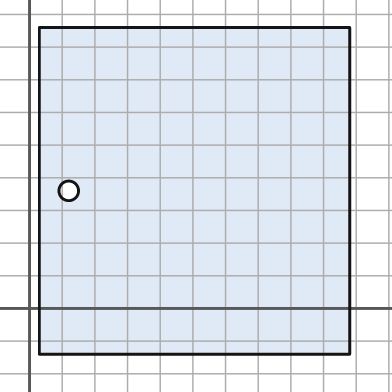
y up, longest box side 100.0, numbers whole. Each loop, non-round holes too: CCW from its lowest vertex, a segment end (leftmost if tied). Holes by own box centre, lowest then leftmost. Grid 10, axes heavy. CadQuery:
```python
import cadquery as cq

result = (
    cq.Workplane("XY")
    .moveTo(3.0, -14.0)
    .lineTo(98.0, -14.0)
    .lineTo(98.0, 86.0)
    .lineTo(3.0, 86.0)
    .close()
    .moveTo(12.0, 36.0)
    .circle(3.0)
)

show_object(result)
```